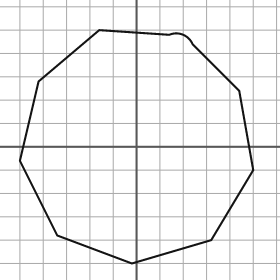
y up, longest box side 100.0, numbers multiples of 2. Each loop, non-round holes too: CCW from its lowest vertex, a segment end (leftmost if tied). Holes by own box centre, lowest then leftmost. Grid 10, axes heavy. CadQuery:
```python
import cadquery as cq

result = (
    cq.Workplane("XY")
    .moveTo(-2.0, -50.0)
    .lineTo(32.0, -40.0)
    .lineTo(50.0, -10.0)
    .lineTo(44.0, 24.0)
    .lineTo(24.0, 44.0)
    .threePointArc((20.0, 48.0), (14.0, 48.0))
    .lineTo(-16.0, 50.0)
    .lineTo(-42.0, 28.0)
    .lineTo(-50.0, -6.0)
    .lineTo(-34.0, -38.0)
    .close()
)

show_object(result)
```